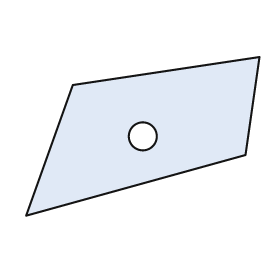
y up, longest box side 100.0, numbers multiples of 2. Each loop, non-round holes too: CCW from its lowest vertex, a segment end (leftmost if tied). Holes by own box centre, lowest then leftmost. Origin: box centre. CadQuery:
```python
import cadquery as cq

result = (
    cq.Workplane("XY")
    .moveTo(-50.0, -34.0)
    .lineTo(44.0, -8.0)
    .lineTo(50.0, 34.0)
    .lineTo(-30.0, 22.0)
    .close()
    .moveTo(0.0, 0.0)
    .circle(6.0)
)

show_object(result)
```